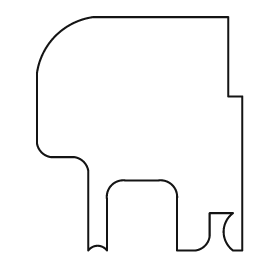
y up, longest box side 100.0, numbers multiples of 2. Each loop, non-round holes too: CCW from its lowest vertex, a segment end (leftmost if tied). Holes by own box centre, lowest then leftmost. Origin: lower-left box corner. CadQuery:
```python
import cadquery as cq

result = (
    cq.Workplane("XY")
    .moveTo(22.0, 0.0)
    .threePointArc((26.0, 2.0), (30.0, 0.0))
    .lineTo(30.0, 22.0)
    .threePointArc((32.0, 28.0), (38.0, 30.0))
    .lineTo(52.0, 30.0)
    .threePointArc((58.0, 28.0), (60.0, 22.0))
    .lineTo(60.0, 0.0)
    .lineTo(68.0, 0.0)
    .threePointArc((72.0, 2.0), (74.0, 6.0))
    .lineTo(74.0, 16.0)
    .lineTo(84.0, 16.0)
    .threePointArc((80.0, 8.0), (84.0, 0.0))
    .lineTo(88.0, 0.0)
    .lineTo(88.0, 66.0)
    .lineTo(82.0, 66.0)
    .lineTo(82.0, 100.0)
    .lineTo(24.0, 100.0)
    .threePointArc((8.0, 92.0), (0.0, 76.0))
    .lineTo(0.0, 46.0)
    .threePointArc((2.0, 42.0), (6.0, 40.0))
    .lineTo(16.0, 40.0)
    .threePointArc((20.0, 38.0), (22.0, 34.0))
    .close()
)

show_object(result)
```